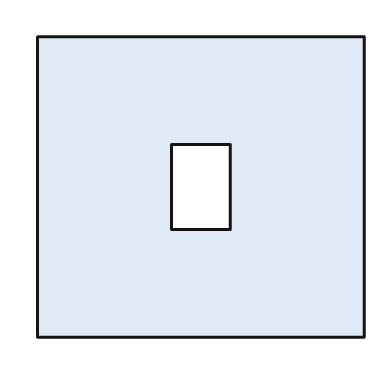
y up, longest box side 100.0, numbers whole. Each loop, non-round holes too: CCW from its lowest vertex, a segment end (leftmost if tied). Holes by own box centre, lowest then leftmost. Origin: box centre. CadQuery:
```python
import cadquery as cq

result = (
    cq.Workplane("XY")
    .moveTo(-50.0, -46.0)
    .lineTo(50.0, -46.0)
    .lineTo(50.0, 46.0)
    .lineTo(-50.0, 46.0)
    .close()
    .moveTo(-9.0, -13.0)
    .lineTo(9.0, -13.0)
    .lineTo(9.0, 13.0)
    .lineTo(-9.0, 13.0)
    .close()
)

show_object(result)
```